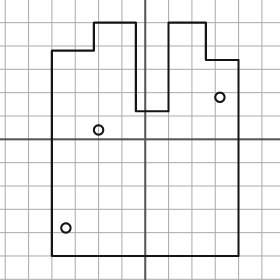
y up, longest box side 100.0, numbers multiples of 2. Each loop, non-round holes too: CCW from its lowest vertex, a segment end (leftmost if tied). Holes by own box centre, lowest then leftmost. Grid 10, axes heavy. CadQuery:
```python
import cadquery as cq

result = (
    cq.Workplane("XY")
    .moveTo(-40.0, -50.0)
    .lineTo(40.0, -50.0)
    .lineTo(40.0, 34.0)
    .lineTo(26.0, 34.0)
    .lineTo(26.0, 50.0)
    .lineTo(10.0, 50.0)
    .lineTo(10.0, 12.0)
    .lineTo(-4.0, 12.0)
    .lineTo(-4.0, 50.0)
    .lineTo(-22.0, 50.0)
    .lineTo(-22.0, 38.0)
    .lineTo(-40.0, 38.0)
    .close()
    .moveTo(-34.0, -38.0)
    .circle(2.0)
    .moveTo(-20.0, 4.0)
    .circle(2.0)
    .moveTo(32.0, 18.0)
    .circle(2.0)
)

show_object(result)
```